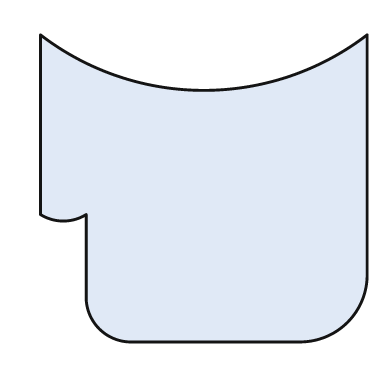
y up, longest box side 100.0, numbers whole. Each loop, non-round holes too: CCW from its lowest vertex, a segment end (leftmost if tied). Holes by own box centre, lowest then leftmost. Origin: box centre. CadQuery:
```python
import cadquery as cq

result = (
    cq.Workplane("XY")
    .moveTo(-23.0, -47.0)
    .lineTo(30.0, -47.0)
    .threePointArc((44.0, -41.0), (50.0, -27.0))
    .lineTo(50.0, 47.0)
    .threePointArc((0.0, 30.0), (-50.0, 47.0))
    .lineTo(-50.0, -8.0)
    .threePointArc((-43.0, -10.0), (-36.0, -8.0))
    .lineTo(-36.0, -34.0)
    .threePointArc((-32.0, -43.0), (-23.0, -47.0))
    .close()
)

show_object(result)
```